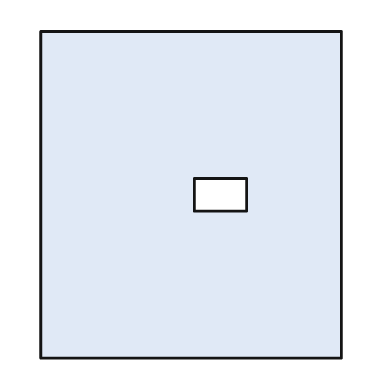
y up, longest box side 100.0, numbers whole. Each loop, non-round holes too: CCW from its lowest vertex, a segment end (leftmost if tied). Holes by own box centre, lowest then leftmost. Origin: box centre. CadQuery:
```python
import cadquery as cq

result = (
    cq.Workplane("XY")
    .moveTo(-46.0, -50.0)
    .lineTo(46.0, -50.0)
    .lineTo(46.0, 50.0)
    .lineTo(-46.0, 50.0)
    .close()
    .moveTo(1.0, -5.0)
    .lineTo(17.0, -5.0)
    .lineTo(17.0, 5.0)
    .lineTo(1.0, 5.0)
    .close()
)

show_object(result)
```